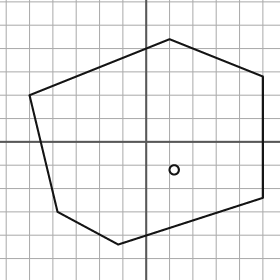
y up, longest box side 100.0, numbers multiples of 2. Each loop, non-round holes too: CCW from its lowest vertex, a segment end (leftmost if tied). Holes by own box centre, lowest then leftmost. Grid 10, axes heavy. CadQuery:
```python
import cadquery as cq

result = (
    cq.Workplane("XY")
    .moveTo(-12.0, -44.0)
    .lineTo(50.0, -24.0)
    .lineTo(50.0, 28.0)
    .lineTo(10.0, 44.0)
    .lineTo(-50.0, 20.0)
    .lineTo(-38.0, -30.0)
    .close()
    .moveTo(12.0, -12.0)
    .circle(2.0)
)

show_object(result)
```